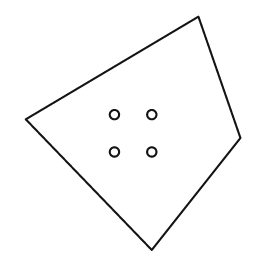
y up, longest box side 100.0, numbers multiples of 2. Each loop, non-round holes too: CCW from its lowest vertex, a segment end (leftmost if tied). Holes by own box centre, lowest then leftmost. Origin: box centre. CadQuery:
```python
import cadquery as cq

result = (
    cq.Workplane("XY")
    .moveTo(8.0, -50.0)
    .lineTo(46.0, -2.0)
    .lineTo(28.0, 50.0)
    .lineTo(-46.0, 6.0)
    .close()
    .moveTo(-8.0, -8.0)
    .circle(2.0)
    .moveTo(8.0, -8.0)
    .circle(2.0)
    .moveTo(-8.0, 8.0)
    .circle(2.0)
    .moveTo(8.0, 8.0)
    .circle(2.0)
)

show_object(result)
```